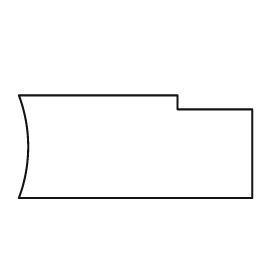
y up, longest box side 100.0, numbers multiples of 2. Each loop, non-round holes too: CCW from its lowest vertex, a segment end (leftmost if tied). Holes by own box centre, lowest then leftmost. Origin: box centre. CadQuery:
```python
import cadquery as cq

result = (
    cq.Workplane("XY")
    .moveTo(-50.0, -22.0)
    .lineTo(50.0, -22.0)
    .lineTo(50.0, 16.0)
    .lineTo(18.0, 16.0)
    .lineTo(18.0, 22.0)
    .lineTo(-50.0, 22.0)
    .threePointArc((-46.0, 0.0), (-50.0, -22.0))
    .close()
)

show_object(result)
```